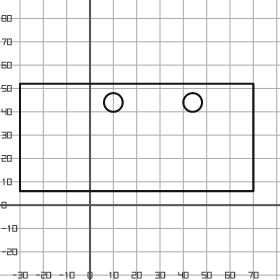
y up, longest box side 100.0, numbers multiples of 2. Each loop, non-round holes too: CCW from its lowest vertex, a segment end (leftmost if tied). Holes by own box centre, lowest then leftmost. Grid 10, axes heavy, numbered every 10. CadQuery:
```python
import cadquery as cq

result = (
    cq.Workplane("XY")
    .moveTo(-30.0, 6.0)
    .lineTo(70.0, 6.0)
    .lineTo(70.0, 52.0)
    .lineTo(-30.0, 52.0)
    .close()
    .moveTo(10.0, 44.0)
    .circle(4.0)
    .moveTo(44.0, 44.0)
    .circle(4.0)
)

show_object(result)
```